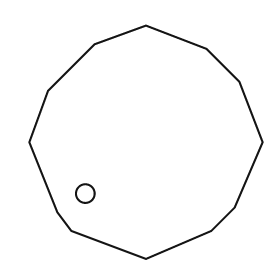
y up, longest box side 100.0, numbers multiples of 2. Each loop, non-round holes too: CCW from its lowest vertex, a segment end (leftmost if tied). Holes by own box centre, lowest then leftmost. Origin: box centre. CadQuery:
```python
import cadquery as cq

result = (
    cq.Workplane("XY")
    .moveTo(0.0, -50.0)
    .lineTo(28.0, -38.0)
    .lineTo(38.0, -28.0)
    .lineTo(50.0, 0.0)
    .lineTo(40.0, 26.0)
    .lineTo(26.0, 40.0)
    .lineTo(0.0, 50.0)
    .lineTo(-22.0, 42.0)
    .lineTo(-42.0, 22.0)
    .lineTo(-50.0, 0.0)
    .lineTo(-38.0, -30.0)
    .lineTo(-32.0, -38.0)
    .close()
    .moveTo(-26.0, -22.0)
    .circle(4.0)
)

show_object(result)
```